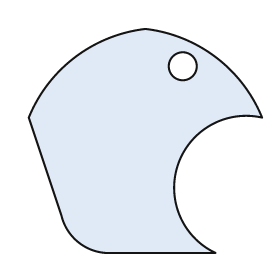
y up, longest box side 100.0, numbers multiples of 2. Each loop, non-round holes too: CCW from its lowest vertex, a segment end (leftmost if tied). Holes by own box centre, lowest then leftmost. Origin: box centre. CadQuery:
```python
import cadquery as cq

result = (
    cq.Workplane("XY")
    .moveTo(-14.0, -48.0)
    .lineTo(30.0, -48.0)
    .threePointArc((14.0, -10.0), (50.0, 10.0))
    .threePointArc((30.0, 36.0), (0.0, 48.0))
    .threePointArc((-30.0, 36.0), (-50.0, 10.0))
    .lineTo(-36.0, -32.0)
    .threePointArc((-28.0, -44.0), (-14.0, -48.0))
    .close()
    .moveTo(16.0, 32.0)
    .circle(6.0)
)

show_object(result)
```